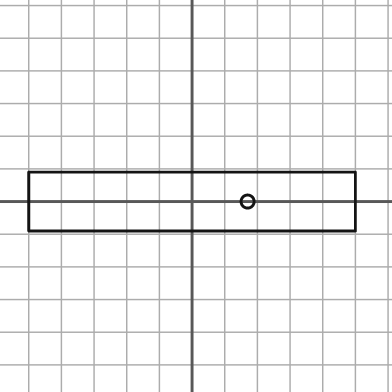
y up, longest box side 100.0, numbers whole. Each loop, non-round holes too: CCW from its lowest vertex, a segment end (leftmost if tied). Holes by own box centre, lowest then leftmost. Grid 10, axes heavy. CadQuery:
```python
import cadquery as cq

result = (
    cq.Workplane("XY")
    .moveTo(-50.0, -9.0)
    .lineTo(50.0, -9.0)
    .lineTo(50.0, 9.0)
    .lineTo(-50.0, 9.0)
    .close()
    .moveTo(17.0, 0.0)
    .circle(2.0)
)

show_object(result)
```